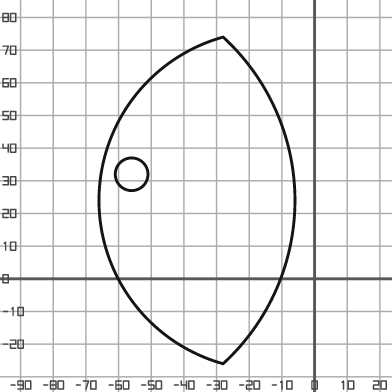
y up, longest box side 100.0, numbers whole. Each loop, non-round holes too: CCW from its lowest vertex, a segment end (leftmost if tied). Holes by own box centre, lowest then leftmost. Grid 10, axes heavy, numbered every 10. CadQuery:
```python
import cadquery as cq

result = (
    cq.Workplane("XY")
    .moveTo(-28.0, -26.0)
    .threePointArc((-6.0, 24.0), (-28.0, 74.0))
    .threePointArc((-66.0, 24.0), (-28.0, -26.0))
    .close()
    .moveTo(-56.0, 32.0)
    .circle(5.0)
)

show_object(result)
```